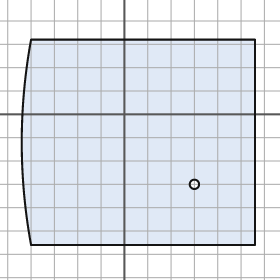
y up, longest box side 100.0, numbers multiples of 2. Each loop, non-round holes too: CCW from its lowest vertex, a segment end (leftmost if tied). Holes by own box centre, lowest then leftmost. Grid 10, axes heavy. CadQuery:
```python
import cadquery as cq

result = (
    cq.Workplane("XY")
    .moveTo(-40.0, -56.0)
    .lineTo(56.0, -56.0)
    .lineTo(56.0, 32.0)
    .lineTo(-40.0, 32.0)
    .threePointArc((-44.0, -12.0), (-40.0, -56.0))
    .close()
    .moveTo(30.0, -30.0)
    .circle(2.0)
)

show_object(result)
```